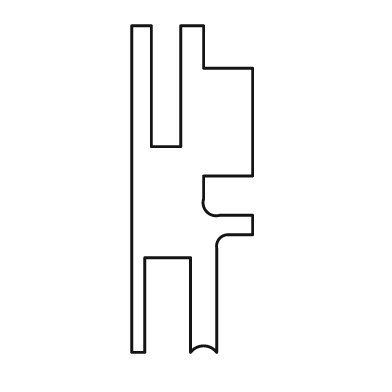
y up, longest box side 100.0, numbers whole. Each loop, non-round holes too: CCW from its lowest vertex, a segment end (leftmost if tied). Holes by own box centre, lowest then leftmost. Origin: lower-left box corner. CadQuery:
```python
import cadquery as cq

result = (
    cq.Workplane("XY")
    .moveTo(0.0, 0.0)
    .lineTo(4.0, 0.0)
    .lineTo(4.0, 29.0)
    .lineTo(18.0, 29.0)
    .lineTo(18.0, 0.0)
    .threePointArc((22.0, 2.0), (26.0, 0.0))
    .lineTo(26.0, 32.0)
    .threePointArc((27.0, 35.0), (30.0, 36.0))
    .lineTo(37.0, 36.0)
    .lineTo(37.0, 42.0)
    .lineTo(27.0, 42.0)
    .threePointArc((23.0, 43.0), (22.0, 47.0))
    .lineTo(22.0, 54.0)
    .lineTo(37.0, 54.0)
    .lineTo(37.0, 87.0)
    .lineTo(22.0, 87.0)
    .lineTo(22.0, 100.0)
    .lineTo(15.0, 100.0)
    .lineTo(15.0, 63.0)
    .lineTo(6.0, 63.0)
    .lineTo(6.0, 100.0)
    .lineTo(0.0, 100.0)
    .close()
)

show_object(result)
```